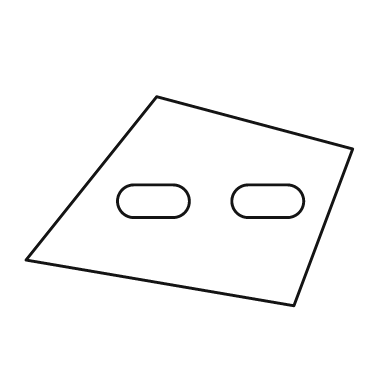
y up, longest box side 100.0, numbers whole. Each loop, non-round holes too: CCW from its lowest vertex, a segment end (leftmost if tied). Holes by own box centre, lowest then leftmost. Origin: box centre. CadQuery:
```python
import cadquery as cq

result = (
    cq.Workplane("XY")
    .moveTo(32.0, -32.0)
    .lineTo(50.0, 16.0)
    .lineTo(-10.0, 32.0)
    .lineTo(-50.0, -18.0)
    .close()
    .moveTo(-17.0, -5.0)
    .lineTo(-5.0, -5.0)
    .threePointArc((0.0, 0.0), (-5.0, 5.0))
    .lineTo(-17.0, 5.0)
    .threePointArc((-22.0, 0.0), (-17.0, -5.0))
    .close()
    .moveTo(18.0, -5.0)
    .lineTo(30.0, -5.0)
    .threePointArc((35.0, 0.0), (30.0, 5.0))
    .lineTo(18.0, 5.0)
    .threePointArc((13.0, 0.0), (18.0, -5.0))
    .close()
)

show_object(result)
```